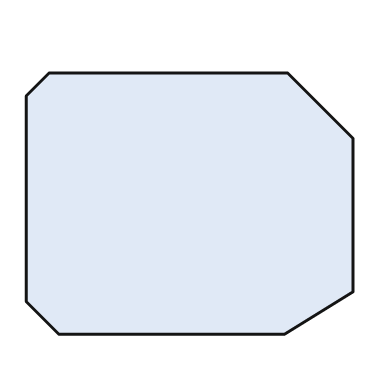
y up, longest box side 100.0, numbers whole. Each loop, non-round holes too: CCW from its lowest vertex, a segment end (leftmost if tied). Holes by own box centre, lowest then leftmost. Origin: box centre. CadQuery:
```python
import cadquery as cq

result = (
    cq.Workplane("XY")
    .moveTo(-40.0, -40.0)
    .lineTo(29.0, -40.0)
    .lineTo(50.0, -27.0)
    .lineTo(50.0, 20.0)
    .lineTo(30.0, 40.0)
    .lineTo(-43.0, 40.0)
    .lineTo(-50.0, 33.0)
    .lineTo(-50.0, -30.0)
    .close()
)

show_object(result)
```